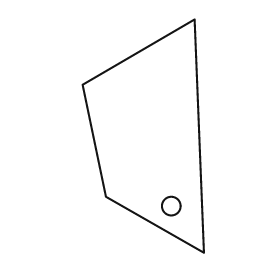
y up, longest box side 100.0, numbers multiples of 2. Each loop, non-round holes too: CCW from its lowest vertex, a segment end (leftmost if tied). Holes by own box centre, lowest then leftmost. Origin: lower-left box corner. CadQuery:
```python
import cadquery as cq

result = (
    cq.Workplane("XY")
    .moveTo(52.0, 0.0)
    .lineTo(48.0, 100.0)
    .lineTo(0.0, 72.0)
    .lineTo(10.0, 24.0)
    .close()
    .moveTo(38.0, 20.0)
    .circle(4.0)
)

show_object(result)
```